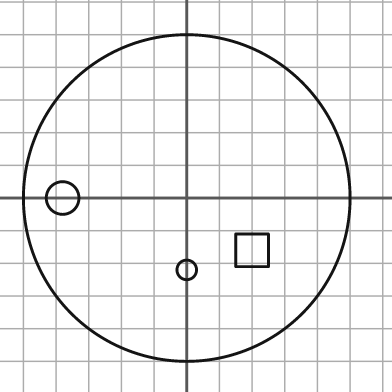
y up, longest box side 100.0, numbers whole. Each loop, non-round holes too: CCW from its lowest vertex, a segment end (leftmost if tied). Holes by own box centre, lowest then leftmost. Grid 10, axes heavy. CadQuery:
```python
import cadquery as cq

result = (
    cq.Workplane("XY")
    .moveTo(0.0, 0.0)
    .circle(50.0)
    .moveTo(0.0, -22.0)
    .circle(3.0)
    .moveTo(15.0, -21.0)
    .lineTo(25.0, -21.0)
    .lineTo(25.0, -11.0)
    .lineTo(15.0, -11.0)
    .close()
    .moveTo(-38.0, 0.0)
    .circle(5.0)
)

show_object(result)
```